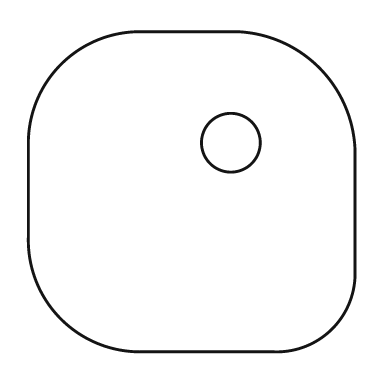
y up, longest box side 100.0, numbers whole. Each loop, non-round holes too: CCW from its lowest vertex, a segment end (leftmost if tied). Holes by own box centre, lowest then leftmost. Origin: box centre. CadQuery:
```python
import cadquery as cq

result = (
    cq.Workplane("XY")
    .moveTo(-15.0, -49.0)
    .lineTo(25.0, -49.0)
    .threePointArc((43.0, -42.0), (50.0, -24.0))
    .lineTo(50.0, 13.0)
    .threePointArc((39.0, 38.0), (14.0, 49.0))
    .lineTo(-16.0, 49.0)
    .threePointArc((-40.0, 39.0), (-50.0, 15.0))
    .lineTo(-50.0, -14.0)
    .threePointArc((-40.0, -39.0), (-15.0, -49.0))
    .close()
    .moveTo(12.0, 15.0)
    .circle(9.0)
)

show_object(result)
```